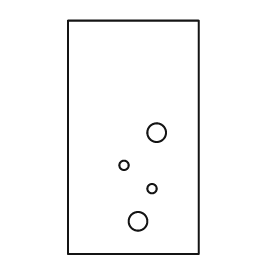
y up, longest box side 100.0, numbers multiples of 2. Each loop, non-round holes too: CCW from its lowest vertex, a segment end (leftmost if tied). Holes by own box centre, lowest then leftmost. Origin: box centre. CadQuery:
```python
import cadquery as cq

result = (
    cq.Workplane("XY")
    .moveTo(-28.0, -50.0)
    .lineTo(28.0, -50.0)
    .lineTo(28.0, 50.0)
    .lineTo(-28.0, 50.0)
    .close()
    .moveTo(2.0, -36.0)
    .circle(4.0)
    .moveTo(8.0, -22.0)
    .circle(2.0)
    .moveTo(-4.0, -12.0)
    .circle(2.0)
    .moveTo(10.0, 2.0)
    .circle(4.0)
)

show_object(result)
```